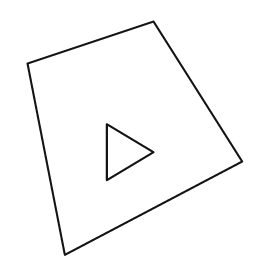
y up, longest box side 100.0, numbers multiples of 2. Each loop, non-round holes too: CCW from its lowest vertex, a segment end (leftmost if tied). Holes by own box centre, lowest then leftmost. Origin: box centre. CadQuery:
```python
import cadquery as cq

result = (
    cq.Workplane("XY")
    .moveTo(-30.0, -50.0)
    .lineTo(46.0, -10.0)
    .lineTo(8.0, 50.0)
    .lineTo(-46.0, 32.0)
    .close()
    .moveTo(-12.0, -18.0)
    .lineTo(8.0, -6.0)
    .lineTo(-12.0, 6.0)
    .close()
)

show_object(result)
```